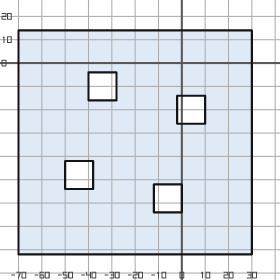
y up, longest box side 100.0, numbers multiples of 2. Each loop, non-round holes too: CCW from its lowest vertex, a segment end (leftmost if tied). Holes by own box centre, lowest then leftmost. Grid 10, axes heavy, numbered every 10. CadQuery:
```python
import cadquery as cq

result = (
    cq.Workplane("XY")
    .moveTo(-70.0, -82.0)
    .lineTo(30.0, -82.0)
    .lineTo(30.0, 14.0)
    .lineTo(-70.0, 14.0)
    .close()
    .moveTo(-12.0, -64.0)
    .lineTo(0.0, -64.0)
    .lineTo(0.0, -52.0)
    .lineTo(-12.0, -52.0)
    .close()
    .moveTo(-50.0, -54.0)
    .lineTo(-38.0, -54.0)
    .lineTo(-38.0, -42.0)
    .lineTo(-50.0, -42.0)
    .close()
    .moveTo(-2.0, -26.0)
    .lineTo(10.0, -26.0)
    .lineTo(10.0, -14.0)
    .lineTo(-2.0, -14.0)
    .close()
    .moveTo(-40.0, -16.0)
    .lineTo(-28.0, -16.0)
    .lineTo(-28.0, -4.0)
    .lineTo(-40.0, -4.0)
    .close()
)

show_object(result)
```